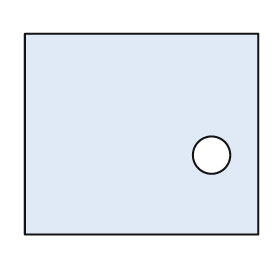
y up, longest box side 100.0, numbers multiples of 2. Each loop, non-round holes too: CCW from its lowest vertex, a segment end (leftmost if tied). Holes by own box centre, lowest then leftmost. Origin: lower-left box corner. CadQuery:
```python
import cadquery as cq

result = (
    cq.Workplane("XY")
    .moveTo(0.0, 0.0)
    .lineTo(100.0, 0.0)
    .lineTo(100.0, 86.0)
    .lineTo(0.0, 86.0)
    .close()
    .moveTo(80.0, 34.0)
    .circle(8.0)
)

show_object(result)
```